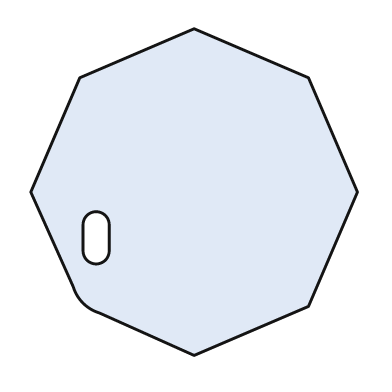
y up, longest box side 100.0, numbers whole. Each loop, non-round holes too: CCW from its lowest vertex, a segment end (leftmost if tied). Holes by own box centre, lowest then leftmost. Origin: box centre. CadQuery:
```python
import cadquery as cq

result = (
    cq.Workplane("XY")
    .moveTo(0.0, -50.0)
    .lineTo(35.0, -35.0)
    .lineTo(50.0, 0.0)
    .lineTo(35.0, 35.0)
    .lineTo(0.0, 50.0)
    .lineTo(-35.0, 35.0)
    .lineTo(-50.0, 0.0)
    .lineTo(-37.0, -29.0)
    .threePointArc((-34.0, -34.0), (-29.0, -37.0))
    .close()
    .moveTo(-34.0, -18.0)
    .threePointArc((-30.0, -22.0), (-26.0, -18.0))
    .lineTo(-26.0, -10.0)
    .threePointArc((-30.0, -6.0), (-34.0, -10.0))
    .close()
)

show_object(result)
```